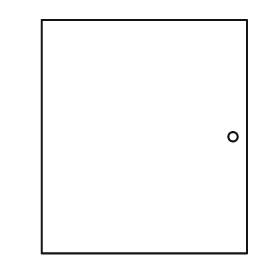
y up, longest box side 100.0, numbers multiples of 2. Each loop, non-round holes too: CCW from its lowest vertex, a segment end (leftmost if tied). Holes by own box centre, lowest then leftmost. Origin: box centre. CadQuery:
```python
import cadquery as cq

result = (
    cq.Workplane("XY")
    .moveTo(-44.0, -50.0)
    .lineTo(44.0, -50.0)
    .lineTo(44.0, 50.0)
    .lineTo(-44.0, 50.0)
    .close()
    .moveTo(38.0, 0.0)
    .circle(2.0)
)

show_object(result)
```